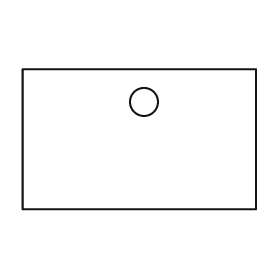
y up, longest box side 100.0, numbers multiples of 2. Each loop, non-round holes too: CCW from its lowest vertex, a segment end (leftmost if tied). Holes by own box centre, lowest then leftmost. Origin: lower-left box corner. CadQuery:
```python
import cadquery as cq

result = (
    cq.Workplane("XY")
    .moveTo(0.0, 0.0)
    .lineTo(100.0, 0.0)
    .lineTo(100.0, 60.0)
    .lineTo(0.0, 60.0)
    .close()
    .moveTo(52.0, 46.0)
    .circle(6.0)
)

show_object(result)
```